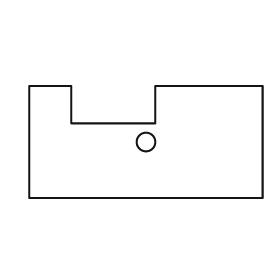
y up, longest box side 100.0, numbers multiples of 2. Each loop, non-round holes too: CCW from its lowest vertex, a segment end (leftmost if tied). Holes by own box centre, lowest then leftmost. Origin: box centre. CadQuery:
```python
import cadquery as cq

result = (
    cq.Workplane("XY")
    .moveTo(-50.0, -24.0)
    .lineTo(50.0, -24.0)
    .lineTo(50.0, 24.0)
    .lineTo(4.0, 24.0)
    .lineTo(4.0, 8.0)
    .lineTo(-32.0, 8.0)
    .lineTo(-32.0, 24.0)
    .lineTo(-50.0, 24.0)
    .close()
    .moveTo(0.0, 0.0)
    .circle(4.0)
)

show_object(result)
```